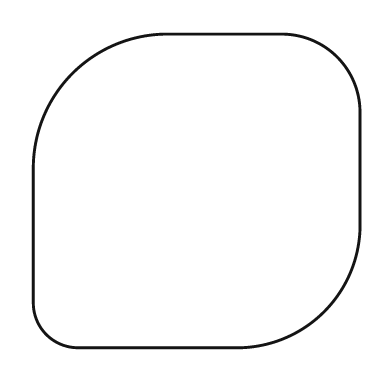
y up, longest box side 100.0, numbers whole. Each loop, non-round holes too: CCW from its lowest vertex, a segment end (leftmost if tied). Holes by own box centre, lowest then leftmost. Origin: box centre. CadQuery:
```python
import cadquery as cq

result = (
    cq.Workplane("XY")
    .moveTo(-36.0, -48.0)
    .lineTo(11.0, -48.0)
    .threePointArc((39.0, -37.0), (50.0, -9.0))
    .lineTo(50.0, 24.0)
    .threePointArc((43.0, 41.0), (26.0, 48.0))
    .lineTo(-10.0, 48.0)
    .threePointArc((-38.0, 36.0), (-50.0, 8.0))
    .lineTo(-50.0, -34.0)
    .threePointArc((-46.0, -44.0), (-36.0, -48.0))
    .close()
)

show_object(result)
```